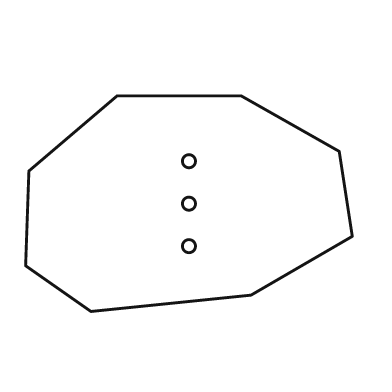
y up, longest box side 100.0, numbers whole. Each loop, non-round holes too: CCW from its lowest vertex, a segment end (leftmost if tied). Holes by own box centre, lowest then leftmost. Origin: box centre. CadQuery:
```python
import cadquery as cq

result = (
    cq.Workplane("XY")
    .moveTo(-30.0, -33.0)
    .lineTo(19.0, -28.0)
    .lineTo(50.0, -10.0)
    .lineTo(46.0, 16.0)
    .lineTo(16.0, 33.0)
    .lineTo(-22.0, 33.0)
    .lineTo(-49.0, 10.0)
    .lineTo(-50.0, -19.0)
    .close()
    .moveTo(0.0, -13.0)
    .circle(2.0)
    .moveTo(0.0, 0.0)
    .circle(2.0)
    .moveTo(0.0, 13.0)
    .circle(2.0)
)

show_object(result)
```